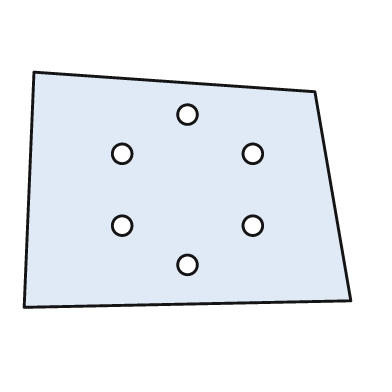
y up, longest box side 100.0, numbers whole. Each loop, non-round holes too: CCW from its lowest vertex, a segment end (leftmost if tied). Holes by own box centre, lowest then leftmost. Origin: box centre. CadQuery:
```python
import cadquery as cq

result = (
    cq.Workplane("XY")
    .moveTo(-50.0, -36.0)
    .lineTo(50.0, -34.0)
    .lineTo(39.0, 30.0)
    .lineTo(-47.0, 36.0)
    .close()
    .moveTo(0.0, -23.0)
    .circle(3.0)
    .moveTo(-20.0, -11.0)
    .circle(3.0)
    .moveTo(20.0, -11.0)
    .circle(3.0)
    .moveTo(-20.0, 11.0)
    .circle(3.0)
    .moveTo(20.0, 11.0)
    .circle(3.0)
    .moveTo(0.0, 23.0)
    .circle(3.0)
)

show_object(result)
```